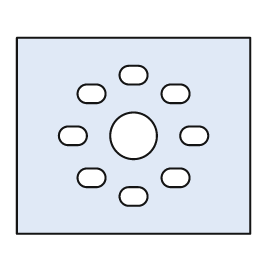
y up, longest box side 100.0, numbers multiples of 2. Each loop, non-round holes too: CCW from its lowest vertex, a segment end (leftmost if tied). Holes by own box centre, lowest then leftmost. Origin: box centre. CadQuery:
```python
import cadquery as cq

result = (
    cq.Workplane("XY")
    .moveTo(-50.0, -42.0)
    .lineTo(50.0, -42.0)
    .lineTo(50.0, 42.0)
    .lineTo(-50.0, 42.0)
    .close()
    .moveTo(-2.0, -30.0)
    .lineTo(2.0, -30.0)
    .threePointArc((6.0, -26.0), (2.0, -22.0))
    .lineTo(-2.0, -22.0)
    .threePointArc((-6.0, -26.0), (-2.0, -30.0))
    .close()
    .moveTo(-20.0, -22.0)
    .lineTo(-16.0, -22.0)
    .threePointArc((-12.0, -18.0), (-16.0, -14.0))
    .lineTo(-20.0, -14.0)
    .threePointArc((-24.0, -18.0), (-20.0, -22.0))
    .close()
    .moveTo(16.0, -22.0)
    .lineTo(20.0, -22.0)
    .threePointArc((24.0, -18.0), (20.0, -14.0))
    .lineTo(16.0, -14.0)
    .threePointArc((12.0, -18.0), (16.0, -22.0))
    .close()
    .moveTo(-28.0, -4.0)
    .lineTo(-24.0, -4.0)
    .threePointArc((-20.0, 0.0), (-24.0, 4.0))
    .lineTo(-28.0, 4.0)
    .threePointArc((-32.0, 0.0), (-28.0, -4.0))
    .close()
    .moveTo(0.0, 0.0)
    .circle(10.0)
    .moveTo(24.0, -4.0)
    .lineTo(28.0, -4.0)
    .threePointArc((32.0, 0.0), (28.0, 4.0))
    .lineTo(24.0, 4.0)
    .threePointArc((20.0, 0.0), (24.0, -4.0))
    .close()
    .moveTo(-20.0, 14.0)
    .lineTo(-16.0, 14.0)
    .threePointArc((-12.0, 18.0), (-16.0, 22.0))
    .lineTo(-20.0, 22.0)
    .threePointArc((-24.0, 18.0), (-20.0, 14.0))
    .close()
    .moveTo(16.0, 14.0)
    .lineTo(20.0, 14.0)
    .threePointArc((24.0, 18.0), (20.0, 22.0))
    .lineTo(16.0, 22.0)
    .threePointArc((12.0, 18.0), (16.0, 14.0))
    .close()
    .moveTo(-2.0, 22.0)
    .lineTo(2.0, 22.0)
    .threePointArc((6.0, 26.0), (2.0, 30.0))
    .lineTo(-2.0, 30.0)
    .threePointArc((-6.0, 26.0), (-2.0, 22.0))
    .close()
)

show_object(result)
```